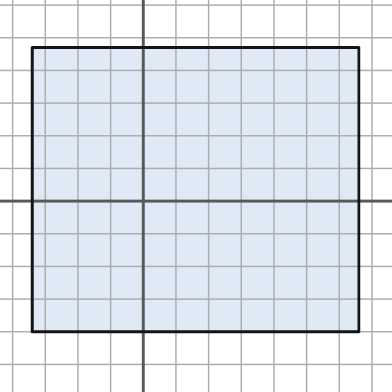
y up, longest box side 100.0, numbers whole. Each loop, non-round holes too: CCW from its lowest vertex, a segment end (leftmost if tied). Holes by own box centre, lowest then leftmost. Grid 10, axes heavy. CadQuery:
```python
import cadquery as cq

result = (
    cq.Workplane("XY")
    .moveTo(-34.0, -40.0)
    .lineTo(66.0, -40.0)
    .lineTo(66.0, 47.0)
    .lineTo(-34.0, 47.0)
    .close()
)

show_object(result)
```